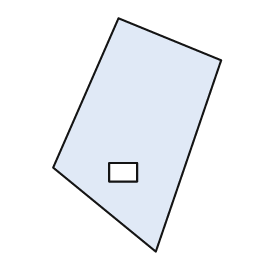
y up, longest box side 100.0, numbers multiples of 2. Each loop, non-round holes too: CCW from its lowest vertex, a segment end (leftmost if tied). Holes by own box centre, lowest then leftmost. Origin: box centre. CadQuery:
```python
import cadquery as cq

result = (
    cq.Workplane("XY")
    .moveTo(8.0, -50.0)
    .lineTo(36.0, 32.0)
    .lineTo(-8.0, 50.0)
    .lineTo(-36.0, -14.0)
    .close()
    .moveTo(-12.0, -20.0)
    .lineTo(0.0, -20.0)
    .lineTo(0.0, -12.0)
    .lineTo(-12.0, -12.0)
    .close()
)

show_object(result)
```